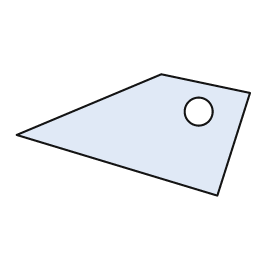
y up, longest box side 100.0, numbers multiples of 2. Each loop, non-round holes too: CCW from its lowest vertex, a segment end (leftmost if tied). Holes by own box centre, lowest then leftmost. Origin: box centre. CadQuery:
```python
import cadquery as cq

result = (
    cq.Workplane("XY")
    .moveTo(36.0, -26.0)
    .lineTo(50.0, 18.0)
    .lineTo(12.0, 26.0)
    .lineTo(-50.0, 0.0)
    .close()
    .moveTo(28.0, 10.0)
    .circle(6.0)
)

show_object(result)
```